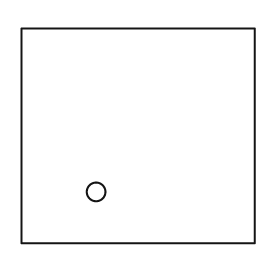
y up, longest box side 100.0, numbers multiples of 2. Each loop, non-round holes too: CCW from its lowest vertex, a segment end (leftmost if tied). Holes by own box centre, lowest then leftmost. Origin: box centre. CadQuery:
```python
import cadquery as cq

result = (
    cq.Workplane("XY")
    .moveTo(-50.0, -46.0)
    .lineTo(50.0, -46.0)
    .lineTo(50.0, 46.0)
    .lineTo(-50.0, 46.0)
    .close()
    .moveTo(-18.0, -24.0)
    .circle(4.0)
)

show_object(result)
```